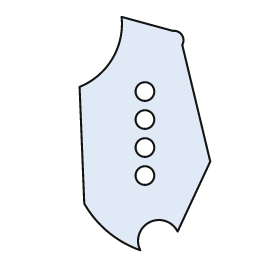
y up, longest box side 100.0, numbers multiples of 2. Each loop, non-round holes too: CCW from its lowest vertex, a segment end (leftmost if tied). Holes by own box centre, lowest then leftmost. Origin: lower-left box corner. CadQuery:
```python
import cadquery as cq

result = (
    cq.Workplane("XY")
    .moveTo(26.0, 0.0)
    .threePointArc((30.0, 12.0), (42.0, 8.0))
    .lineTo(56.0, 38.0)
    .lineTo(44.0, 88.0)
    .threePointArc((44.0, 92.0), (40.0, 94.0))
    .lineTo(18.0, 100.0)
    .threePointArc((14.0, 82.0), (0.0, 70.0))
    .lineTo(2.0, 20.0)
    .threePointArc((12.0, 8.0), (26.0, 0.0))
    .close()
    .moveTo(28.0, 32.0)
    .circle(4.0)
    .moveTo(28.0, 44.0)
    .circle(4.0)
    .moveTo(28.0, 56.0)
    .circle(4.0)
    .moveTo(28.0, 68.0)
    .circle(4.0)
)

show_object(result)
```